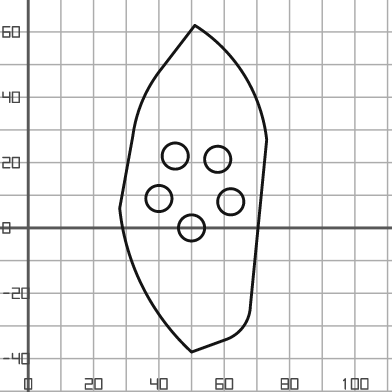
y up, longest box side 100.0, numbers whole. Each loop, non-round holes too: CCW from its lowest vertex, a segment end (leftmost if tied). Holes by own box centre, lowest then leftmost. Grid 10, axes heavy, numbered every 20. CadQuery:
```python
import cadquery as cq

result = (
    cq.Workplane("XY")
    .moveTo(50.0, -38.0)
    .lineTo(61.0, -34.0)
    .threePointArc((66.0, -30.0), (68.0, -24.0))
    .lineTo(73.0, 27.0)
    .threePointArc((66.0, 47.0), (51.0, 62.0))
    .lineTo(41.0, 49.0)
    .threePointArc((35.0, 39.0), (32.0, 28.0))
    .lineTo(28.0, 6.0)
    .threePointArc((35.0, -18.0), (50.0, -38.0))
    .close()
    .moveTo(50.0, 0.0)
    .circle(4.0)
    .moveTo(62.0, 8.0)
    .circle(4.0)
    .moveTo(40.0, 9.0)
    .circle(4.0)
    .moveTo(58.0, 21.0)
    .circle(4.0)
    .moveTo(45.0, 22.0)
    .circle(4.0)
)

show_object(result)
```